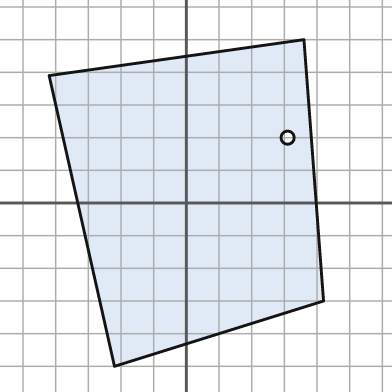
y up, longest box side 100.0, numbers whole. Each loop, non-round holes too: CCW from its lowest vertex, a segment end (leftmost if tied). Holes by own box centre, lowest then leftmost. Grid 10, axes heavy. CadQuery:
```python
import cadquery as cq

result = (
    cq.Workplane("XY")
    .moveTo(-22.0, -50.0)
    .lineTo(42.0, -30.0)
    .lineTo(36.0, 50.0)
    .lineTo(-42.0, 39.0)
    .close()
    .moveTo(31.0, 20.0)
    .circle(2.0)
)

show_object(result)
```